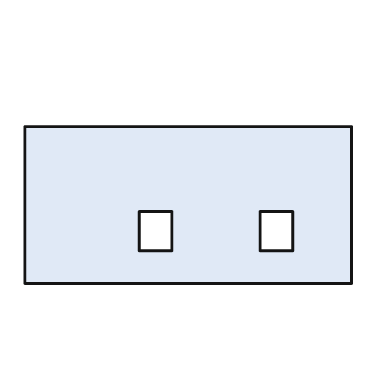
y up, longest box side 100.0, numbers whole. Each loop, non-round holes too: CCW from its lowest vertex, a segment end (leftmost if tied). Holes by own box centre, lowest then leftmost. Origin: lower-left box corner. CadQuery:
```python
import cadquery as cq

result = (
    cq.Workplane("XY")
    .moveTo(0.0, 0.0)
    .lineTo(100.0, 0.0)
    .lineTo(100.0, 48.0)
    .lineTo(0.0, 48.0)
    .close()
    .moveTo(35.0, 10.0)
    .lineTo(45.0, 10.0)
    .lineTo(45.0, 22.0)
    .lineTo(35.0, 22.0)
    .close()
    .moveTo(72.0, 10.0)
    .lineTo(82.0, 10.0)
    .lineTo(82.0, 22.0)
    .lineTo(72.0, 22.0)
    .close()
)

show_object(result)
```